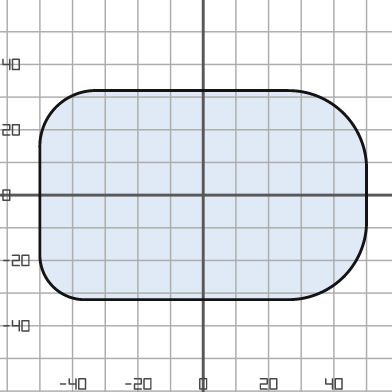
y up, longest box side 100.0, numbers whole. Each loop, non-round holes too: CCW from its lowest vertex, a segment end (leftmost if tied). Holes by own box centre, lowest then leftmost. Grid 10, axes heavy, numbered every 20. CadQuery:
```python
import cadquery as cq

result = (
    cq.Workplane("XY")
    .moveTo(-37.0, -32.0)
    .lineTo(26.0, -32.0)
    .threePointArc((43.0, -25.0), (50.0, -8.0))
    .lineTo(50.0, 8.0)
    .threePointArc((43.0, 25.0), (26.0, 32.0))
    .lineTo(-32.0, 32.0)
    .threePointArc((-45.0, 27.0), (-50.0, 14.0))
    .lineTo(-50.0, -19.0)
    .threePointArc((-46.0, -28.0), (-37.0, -32.0))
    .close()
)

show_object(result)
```